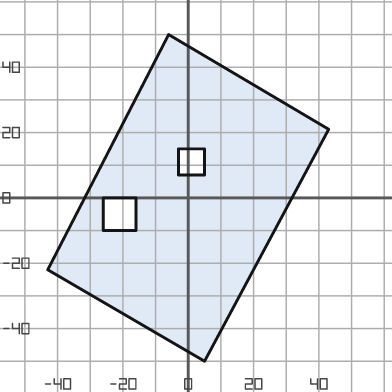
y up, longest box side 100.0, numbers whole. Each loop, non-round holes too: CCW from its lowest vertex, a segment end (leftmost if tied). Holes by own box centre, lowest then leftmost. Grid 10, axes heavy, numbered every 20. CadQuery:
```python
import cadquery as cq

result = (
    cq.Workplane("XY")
    .moveTo(5.0, -50.0)
    .lineTo(43.0, 21.0)
    .lineTo(-6.0, 50.0)
    .lineTo(-43.0, -22.0)
    .close()
    .moveTo(-26.0, -10.0)
    .lineTo(-16.0, -10.0)
    .lineTo(-16.0, 0.0)
    .lineTo(-26.0, 0.0)
    .close()
    .moveTo(-3.0, 7.0)
    .lineTo(5.0, 7.0)
    .lineTo(5.0, 15.0)
    .lineTo(-3.0, 15.0)
    .close()
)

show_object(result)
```